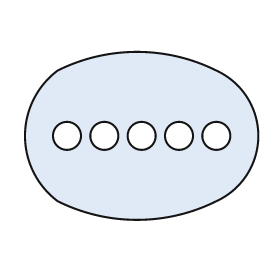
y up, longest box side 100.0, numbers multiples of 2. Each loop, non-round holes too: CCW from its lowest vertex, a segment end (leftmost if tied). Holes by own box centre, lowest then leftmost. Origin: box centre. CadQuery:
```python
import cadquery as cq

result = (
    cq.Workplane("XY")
    .moveTo(-36.0, -28.0)
    .threePointArc((-2.0, -36.0), (32.0, -28.0))
    .threePointArc((50.0, 0.0), (32.0, 28.0))
    .threePointArc((-2.0, 36.0), (-36.0, 28.0))
    .threePointArc((-50.0, 0.0), (-36.0, -28.0))
    .close()
    .moveTo(-32.0, 0.0)
    .circle(6.0)
    .moveTo(-16.0, 0.0)
    .circle(6.0)
    .moveTo(0.0, 0.0)
    .circle(6.0)
    .moveTo(16.0, 0.0)
    .circle(6.0)
    .moveTo(32.0, 0.0)
    .circle(6.0)
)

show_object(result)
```